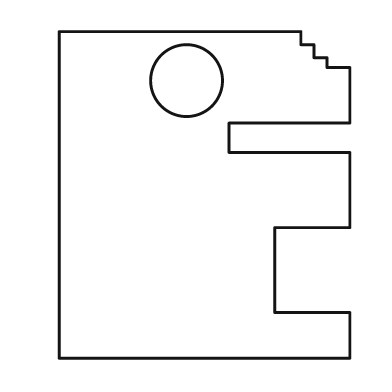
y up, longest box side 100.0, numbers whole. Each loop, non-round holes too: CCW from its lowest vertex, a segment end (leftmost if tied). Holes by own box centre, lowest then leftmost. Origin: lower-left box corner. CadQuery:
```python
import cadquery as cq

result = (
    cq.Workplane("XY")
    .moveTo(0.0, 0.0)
    .lineTo(89.0, 0.0)
    .lineTo(89.0, 14.0)
    .lineTo(66.0, 14.0)
    .lineTo(66.0, 40.0)
    .lineTo(89.0, 40.0)
    .lineTo(89.0, 63.0)
    .lineTo(52.0, 63.0)
    .lineTo(52.0, 72.0)
    .lineTo(89.0, 72.0)
    .lineTo(89.0, 89.0)
    .lineTo(82.0, 89.0)
    .lineTo(82.0, 92.0)
    .lineTo(78.0, 92.0)
    .lineTo(78.0, 96.0)
    .lineTo(74.0, 96.0)
    .lineTo(74.0, 100.0)
    .lineTo(0.0, 100.0)
    .close()
    .moveTo(39.0, 85.0)
    .circle(11.0)
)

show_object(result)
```